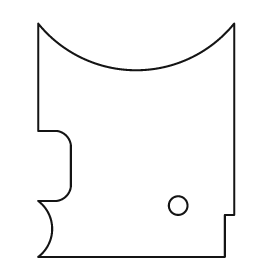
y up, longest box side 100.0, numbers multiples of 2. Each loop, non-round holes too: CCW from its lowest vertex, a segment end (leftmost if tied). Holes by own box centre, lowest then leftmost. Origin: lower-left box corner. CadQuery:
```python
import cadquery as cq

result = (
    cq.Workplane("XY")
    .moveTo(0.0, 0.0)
    .lineTo(80.0, 0.0)
    .lineTo(80.0, 18.0)
    .lineTo(84.0, 18.0)
    .lineTo(84.0, 100.0)
    .threePointArc((42.0, 80.0), (0.0, 100.0))
    .lineTo(0.0, 54.0)
    .lineTo(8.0, 54.0)
    .threePointArc((12.0, 52.0), (14.0, 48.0))
    .lineTo(14.0, 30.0)
    .threePointArc((12.0, 26.0), (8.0, 24.0))
    .lineTo(0.0, 24.0)
    .threePointArc((6.0, 12.0), (0.0, 0.0))
    .close()
    .moveTo(60.0, 22.0)
    .circle(4.0)
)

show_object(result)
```